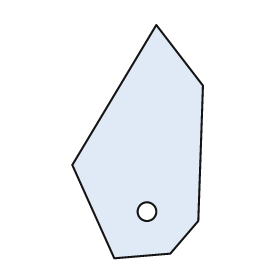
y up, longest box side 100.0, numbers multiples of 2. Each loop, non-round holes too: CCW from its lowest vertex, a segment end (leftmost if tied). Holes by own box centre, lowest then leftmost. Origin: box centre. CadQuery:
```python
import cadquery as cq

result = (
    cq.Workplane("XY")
    .moveTo(-10.0, -50.0)
    .lineTo(14.0, -48.0)
    .lineTo(26.0, -34.0)
    .lineTo(28.0, 24.0)
    .lineTo(8.0, 50.0)
    .lineTo(-28.0, -10.0)
    .close()
    .moveTo(4.0, -30.0)
    .circle(4.0)
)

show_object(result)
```